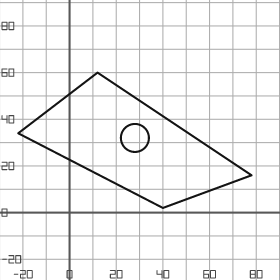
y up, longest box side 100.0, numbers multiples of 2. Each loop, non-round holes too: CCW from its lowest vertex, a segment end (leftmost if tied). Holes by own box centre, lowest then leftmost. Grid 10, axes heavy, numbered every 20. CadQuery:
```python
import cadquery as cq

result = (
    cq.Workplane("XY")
    .moveTo(40.0, 2.0)
    .lineTo(78.0, 16.0)
    .lineTo(12.0, 60.0)
    .lineTo(-22.0, 34.0)
    .close()
    .moveTo(28.0, 32.0)
    .circle(6.0)
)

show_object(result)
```